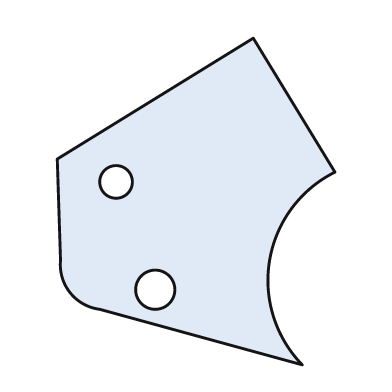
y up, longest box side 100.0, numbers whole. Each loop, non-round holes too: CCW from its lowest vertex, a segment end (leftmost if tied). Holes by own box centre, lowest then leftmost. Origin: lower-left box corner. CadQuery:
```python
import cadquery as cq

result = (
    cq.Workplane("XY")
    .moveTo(75.0, 0.0)
    .threePointArc((65.0, 32.0), (85.0, 59.0))
    .lineTo(60.0, 100.0)
    .lineTo(0.0, 63.0)
    .lineTo(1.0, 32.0)
    .threePointArc((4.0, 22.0), (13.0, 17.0))
    .close()
    .moveTo(30.0, 23.0)
    .circle(6.0)
    .moveTo(18.0, 56.0)
    .circle(5.0)
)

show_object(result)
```